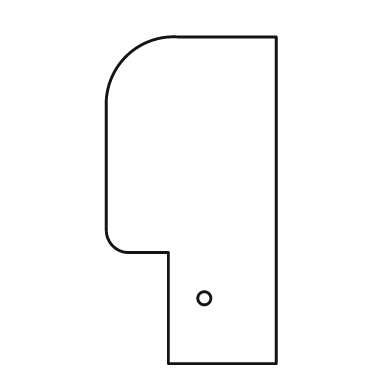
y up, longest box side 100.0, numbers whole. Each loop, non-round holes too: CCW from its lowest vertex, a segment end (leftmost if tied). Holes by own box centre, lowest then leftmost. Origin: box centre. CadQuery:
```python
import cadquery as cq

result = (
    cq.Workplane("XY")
    .moveTo(-7.0, -50.0)
    .lineTo(26.0, -50.0)
    .lineTo(26.0, 50.0)
    .lineTo(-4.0, 50.0)
    .threePointArc((-20.0, 44.0), (-26.0, 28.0))
    .lineTo(-26.0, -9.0)
    .threePointArc((-24.0, -14.0), (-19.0, -16.0))
    .lineTo(-7.0, -16.0)
    .close()
    .moveTo(4.0, -30.0)
    .circle(2.0)
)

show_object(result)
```